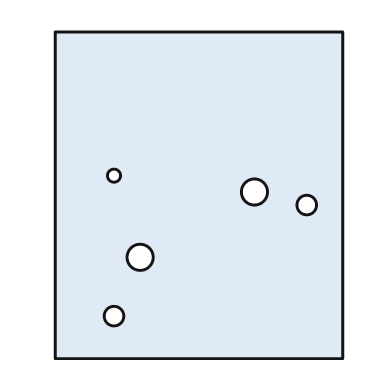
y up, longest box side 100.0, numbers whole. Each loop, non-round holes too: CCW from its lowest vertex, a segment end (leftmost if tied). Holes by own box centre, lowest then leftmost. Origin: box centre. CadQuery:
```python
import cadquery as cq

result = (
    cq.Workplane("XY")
    .moveTo(-44.0, -50.0)
    .lineTo(44.0, -50.0)
    .lineTo(44.0, 50.0)
    .lineTo(-44.0, 50.0)
    .close()
    .moveTo(-26.0, -37.0)
    .circle(3.0)
    .moveTo(-18.0, -19.0)
    .circle(4.0)
    .moveTo(33.0, -3.0)
    .circle(3.0)
    .moveTo(17.0, 1.0)
    .circle(4.0)
    .moveTo(-26.0, 6.0)
    .circle(2.0)
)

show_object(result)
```